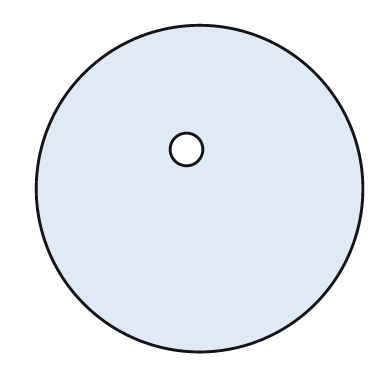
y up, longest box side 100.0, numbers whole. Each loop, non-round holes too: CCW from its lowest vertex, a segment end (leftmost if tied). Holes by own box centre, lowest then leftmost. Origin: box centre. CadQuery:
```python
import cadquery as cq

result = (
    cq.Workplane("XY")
    .moveTo(0.0, 0.0)
    .circle(50.0)
    .moveTo(-4.0, 12.0)
    .circle(5.0)
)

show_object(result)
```